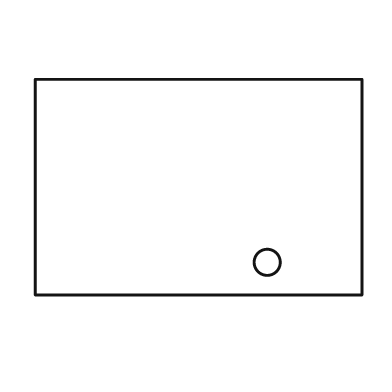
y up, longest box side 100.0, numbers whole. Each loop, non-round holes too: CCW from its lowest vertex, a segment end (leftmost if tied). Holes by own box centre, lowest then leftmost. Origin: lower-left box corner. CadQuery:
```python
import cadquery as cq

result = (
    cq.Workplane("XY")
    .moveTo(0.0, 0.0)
    .lineTo(100.0, 0.0)
    .lineTo(100.0, 66.0)
    .lineTo(0.0, 66.0)
    .close()
    .moveTo(71.0, 10.0)
    .circle(4.0)
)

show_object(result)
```